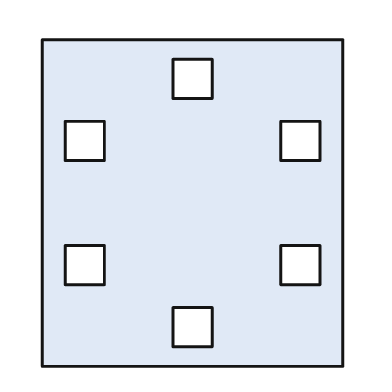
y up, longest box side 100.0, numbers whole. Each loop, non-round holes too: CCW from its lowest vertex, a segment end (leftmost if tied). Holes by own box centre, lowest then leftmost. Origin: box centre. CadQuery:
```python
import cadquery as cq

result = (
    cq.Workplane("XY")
    .moveTo(-46.0, -50.0)
    .lineTo(46.0, -50.0)
    .lineTo(46.0, 50.0)
    .lineTo(-46.0, 50.0)
    .close()
    .moveTo(-6.0, -44.0)
    .lineTo(6.0, -44.0)
    .lineTo(6.0, -32.0)
    .lineTo(-6.0, -32.0)
    .close()
    .moveTo(-39.0, -25.0)
    .lineTo(-27.0, -25.0)
    .lineTo(-27.0, -13.0)
    .lineTo(-39.0, -13.0)
    .close()
    .moveTo(27.0, -25.0)
    .lineTo(39.0, -25.0)
    .lineTo(39.0, -13.0)
    .lineTo(27.0, -13.0)
    .close()
    .moveTo(-39.0, 13.0)
    .lineTo(-27.0, 13.0)
    .lineTo(-27.0, 25.0)
    .lineTo(-39.0, 25.0)
    .close()
    .moveTo(27.0, 13.0)
    .lineTo(39.0, 13.0)
    .lineTo(39.0, 25.0)
    .lineTo(27.0, 25.0)
    .close()
    .moveTo(-6.0, 32.0)
    .lineTo(6.0, 32.0)
    .lineTo(6.0, 44.0)
    .lineTo(-6.0, 44.0)
    .close()
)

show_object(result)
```